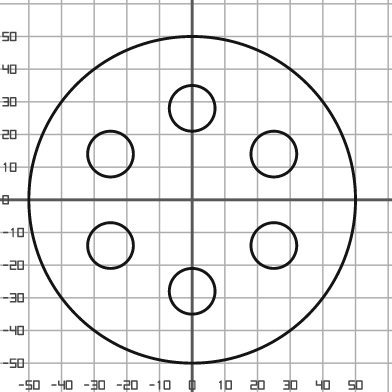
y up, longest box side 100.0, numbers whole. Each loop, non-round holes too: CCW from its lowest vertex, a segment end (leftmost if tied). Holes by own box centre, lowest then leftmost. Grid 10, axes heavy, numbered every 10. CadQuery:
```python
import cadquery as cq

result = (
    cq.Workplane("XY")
    .moveTo(0.0, 0.0)
    .circle(50.0)
    .moveTo(0.0, -28.0)
    .circle(7.0)
    .moveTo(-25.0, -14.0)
    .circle(7.0)
    .moveTo(25.0, -14.0)
    .circle(7.0)
    .moveTo(-25.0, 14.0)
    .circle(7.0)
    .moveTo(25.0, 14.0)
    .circle(7.0)
    .moveTo(0.0, 28.0)
    .circle(7.0)
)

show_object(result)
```